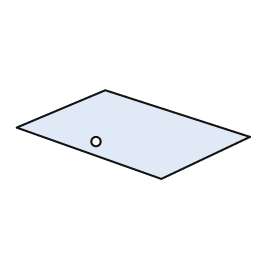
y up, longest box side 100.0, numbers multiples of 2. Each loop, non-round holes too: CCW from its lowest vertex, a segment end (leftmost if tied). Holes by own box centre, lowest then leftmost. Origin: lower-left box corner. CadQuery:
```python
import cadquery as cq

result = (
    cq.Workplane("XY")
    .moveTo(62.0, 0.0)
    .lineTo(100.0, 18.0)
    .lineTo(38.0, 38.0)
    .lineTo(0.0, 22.0)
    .close()
    .moveTo(34.0, 16.0)
    .circle(2.0)
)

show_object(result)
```